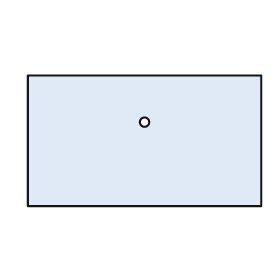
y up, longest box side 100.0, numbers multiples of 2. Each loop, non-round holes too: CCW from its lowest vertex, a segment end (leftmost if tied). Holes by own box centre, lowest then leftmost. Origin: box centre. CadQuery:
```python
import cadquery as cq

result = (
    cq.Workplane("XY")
    .moveTo(-50.0, -28.0)
    .lineTo(50.0, -28.0)
    .lineTo(50.0, 28.0)
    .lineTo(-50.0, 28.0)
    .close()
    .moveTo(0.0, 8.0)
    .circle(2.0)
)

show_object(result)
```